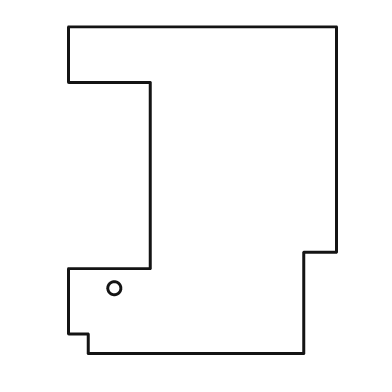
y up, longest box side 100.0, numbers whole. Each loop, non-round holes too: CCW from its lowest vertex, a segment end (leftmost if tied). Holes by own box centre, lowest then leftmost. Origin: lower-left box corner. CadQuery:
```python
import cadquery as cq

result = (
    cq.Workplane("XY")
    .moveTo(6.0, 0.0)
    .lineTo(72.0, 0.0)
    .lineTo(72.0, 31.0)
    .lineTo(82.0, 31.0)
    .lineTo(82.0, 100.0)
    .lineTo(0.0, 100.0)
    .lineTo(0.0, 83.0)
    .lineTo(25.0, 83.0)
    .lineTo(25.0, 26.0)
    .lineTo(0.0, 26.0)
    .lineTo(0.0, 6.0)
    .lineTo(6.0, 6.0)
    .close()
    .moveTo(14.0, 20.0)
    .circle(2.0)
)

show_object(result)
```